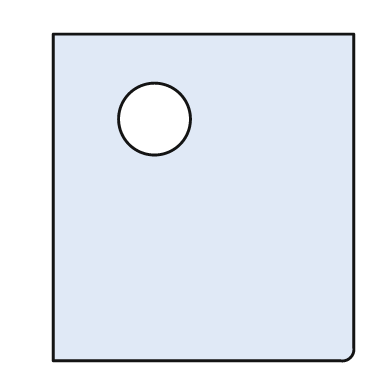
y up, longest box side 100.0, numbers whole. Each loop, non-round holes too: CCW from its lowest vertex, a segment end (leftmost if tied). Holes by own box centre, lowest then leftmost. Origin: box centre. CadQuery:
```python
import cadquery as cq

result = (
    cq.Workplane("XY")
    .moveTo(-46.0, -50.0)
    .lineTo(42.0, -50.0)
    .threePointArc((45.0, -49.0), (46.0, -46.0))
    .lineTo(46.0, 50.0)
    .lineTo(-46.0, 50.0)
    .close()
    .moveTo(-15.0, 24.0)
    .circle(11.0)
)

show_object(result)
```